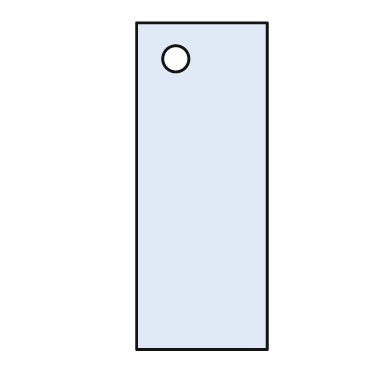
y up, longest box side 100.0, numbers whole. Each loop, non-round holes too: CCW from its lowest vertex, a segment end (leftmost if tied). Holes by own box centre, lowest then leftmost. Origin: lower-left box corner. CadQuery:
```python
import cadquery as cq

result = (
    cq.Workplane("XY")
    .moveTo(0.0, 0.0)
    .lineTo(40.0, 0.0)
    .lineTo(40.0, 100.0)
    .lineTo(0.0, 100.0)
    .close()
    .moveTo(12.0, 89.0)
    .circle(4.0)
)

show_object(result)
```